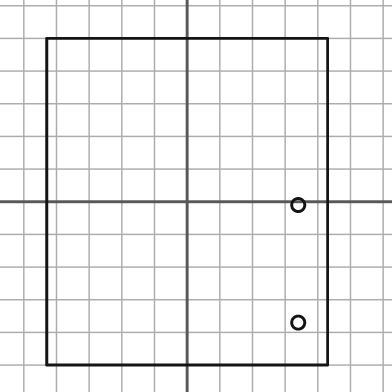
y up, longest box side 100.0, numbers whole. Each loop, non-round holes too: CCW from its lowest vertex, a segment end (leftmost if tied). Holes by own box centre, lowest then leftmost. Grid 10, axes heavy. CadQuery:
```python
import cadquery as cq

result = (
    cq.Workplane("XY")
    .moveTo(-43.0, -50.0)
    .lineTo(43.0, -50.0)
    .lineTo(43.0, 50.0)
    .lineTo(-43.0, 50.0)
    .close()
    .moveTo(34.0, -37.0)
    .circle(2.0)
    .moveTo(34.0, -1.0)
    .circle(2.0)
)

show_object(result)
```